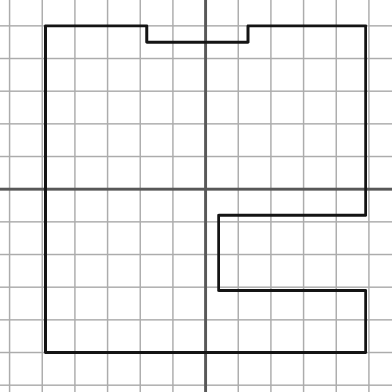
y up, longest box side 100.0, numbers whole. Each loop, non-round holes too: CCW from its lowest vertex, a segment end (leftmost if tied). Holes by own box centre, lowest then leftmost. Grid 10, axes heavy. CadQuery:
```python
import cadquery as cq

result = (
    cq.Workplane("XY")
    .moveTo(-49.0, -50.0)
    .lineTo(49.0, -50.0)
    .lineTo(49.0, -31.0)
    .lineTo(4.0, -31.0)
    .lineTo(4.0, -8.0)
    .lineTo(49.0, -8.0)
    .lineTo(49.0, 50.0)
    .lineTo(13.0, 50.0)
    .lineTo(13.0, 45.0)
    .lineTo(-18.0, 45.0)
    .lineTo(-18.0, 50.0)
    .lineTo(-49.0, 50.0)
    .close()
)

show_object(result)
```